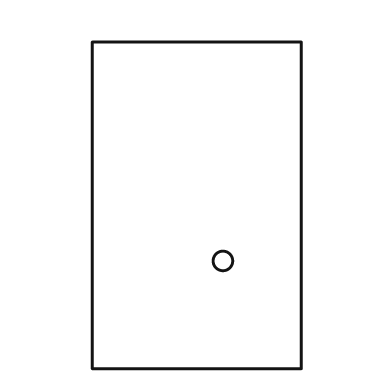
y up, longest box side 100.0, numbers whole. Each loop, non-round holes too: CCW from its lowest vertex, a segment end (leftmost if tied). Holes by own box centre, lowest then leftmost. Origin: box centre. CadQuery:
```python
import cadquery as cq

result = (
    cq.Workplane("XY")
    .moveTo(-32.0, -50.0)
    .lineTo(32.0, -50.0)
    .lineTo(32.0, 50.0)
    .lineTo(-32.0, 50.0)
    .close()
    .moveTo(8.0, -17.0)
    .circle(3.0)
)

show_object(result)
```